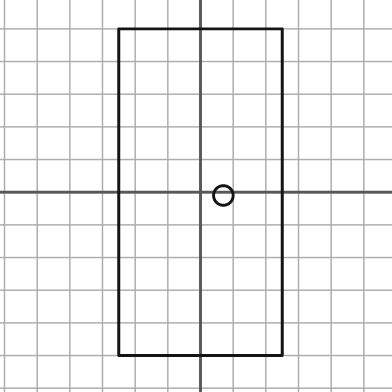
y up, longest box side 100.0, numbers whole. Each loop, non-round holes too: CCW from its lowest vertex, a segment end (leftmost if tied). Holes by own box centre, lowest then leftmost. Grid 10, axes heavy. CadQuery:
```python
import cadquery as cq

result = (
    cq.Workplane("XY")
    .moveTo(-25.0, -50.0)
    .lineTo(25.0, -50.0)
    .lineTo(25.0, 50.0)
    .lineTo(-25.0, 50.0)
    .close()
    .moveTo(7.0, -1.0)
    .circle(3.0)
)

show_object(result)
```